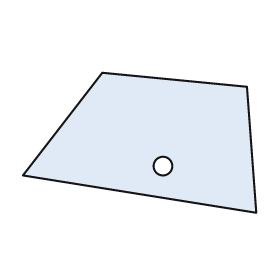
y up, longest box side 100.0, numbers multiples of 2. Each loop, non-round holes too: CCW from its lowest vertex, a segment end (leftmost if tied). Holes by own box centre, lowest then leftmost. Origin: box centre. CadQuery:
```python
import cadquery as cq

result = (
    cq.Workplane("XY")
    .moveTo(50.0, -30.0)
    .lineTo(46.0, 24.0)
    .lineTo(-16.0, 30.0)
    .lineTo(-50.0, -14.0)
    .close()
    .moveTo(10.0, -10.0)
    .circle(4.0)
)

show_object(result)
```